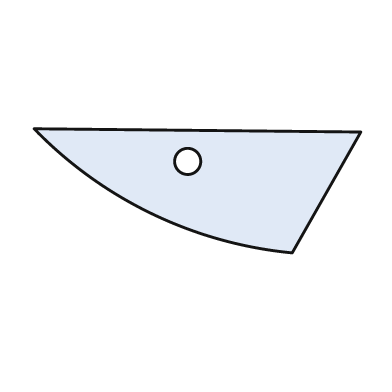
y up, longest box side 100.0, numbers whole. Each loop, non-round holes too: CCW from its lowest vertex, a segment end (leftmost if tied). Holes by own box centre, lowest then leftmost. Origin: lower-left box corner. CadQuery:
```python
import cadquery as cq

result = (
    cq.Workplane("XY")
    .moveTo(79.0, 0.0)
    .lineTo(100.0, 37.0)
    .lineTo(0.0, 38.0)
    .threePointArc((36.0, 12.0), (79.0, 0.0))
    .close()
    .moveTo(47.0, 28.0)
    .circle(4.0)
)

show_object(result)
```